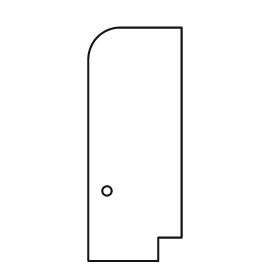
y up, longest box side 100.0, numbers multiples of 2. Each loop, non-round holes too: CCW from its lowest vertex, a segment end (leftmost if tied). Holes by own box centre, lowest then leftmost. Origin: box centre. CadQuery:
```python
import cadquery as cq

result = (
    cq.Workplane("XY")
    .moveTo(-20.0, -50.0)
    .lineTo(10.0, -50.0)
    .lineTo(10.0, -40.0)
    .lineTo(20.0, -40.0)
    .lineTo(20.0, 50.0)
    .lineTo(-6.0, 50.0)
    .threePointArc((-16.0, 46.0), (-20.0, 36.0))
    .close()
    .moveTo(-12.0, -20.0)
    .circle(2.0)
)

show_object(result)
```